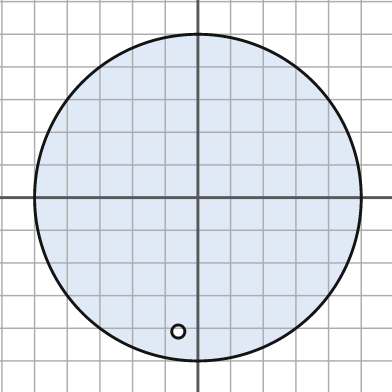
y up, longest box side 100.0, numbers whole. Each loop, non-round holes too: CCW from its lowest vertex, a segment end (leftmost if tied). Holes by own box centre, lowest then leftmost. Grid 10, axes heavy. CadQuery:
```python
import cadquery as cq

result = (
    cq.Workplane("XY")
    .moveTo(0.0, 0.0)
    .circle(50.0)
    .moveTo(-6.0, -41.0)
    .circle(2.0)
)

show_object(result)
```